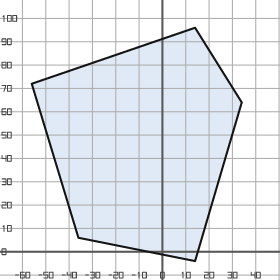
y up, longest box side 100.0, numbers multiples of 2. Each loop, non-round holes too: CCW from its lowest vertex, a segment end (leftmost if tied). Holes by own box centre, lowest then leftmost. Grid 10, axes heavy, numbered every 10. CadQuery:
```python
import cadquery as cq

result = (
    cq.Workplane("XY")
    .moveTo(14.0, -4.0)
    .lineTo(34.0, 64.0)
    .lineTo(14.0, 96.0)
    .lineTo(-56.0, 72.0)
    .lineTo(-36.0, 6.0)
    .close()
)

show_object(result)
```